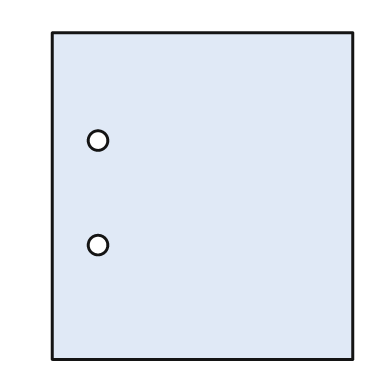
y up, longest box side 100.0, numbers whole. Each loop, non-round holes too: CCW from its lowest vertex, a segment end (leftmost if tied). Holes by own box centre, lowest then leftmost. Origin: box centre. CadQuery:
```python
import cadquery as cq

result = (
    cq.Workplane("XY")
    .moveTo(-46.0, -50.0)
    .lineTo(46.0, -50.0)
    .lineTo(46.0, 50.0)
    .lineTo(-46.0, 50.0)
    .close()
    .moveTo(-32.0, -15.0)
    .circle(3.0)
    .moveTo(-32.0, 17.0)
    .circle(3.0)
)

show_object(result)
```